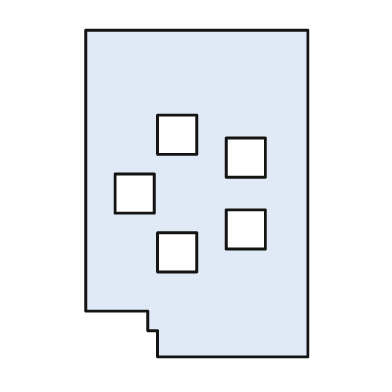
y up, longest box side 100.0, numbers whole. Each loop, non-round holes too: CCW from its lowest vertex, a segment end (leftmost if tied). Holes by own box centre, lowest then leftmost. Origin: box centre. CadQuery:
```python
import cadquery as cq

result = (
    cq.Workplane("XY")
    .moveTo(-12.0, -50.0)
    .lineTo(34.0, -50.0)
    .lineTo(34.0, 50.0)
    .lineTo(-34.0, 50.0)
    .lineTo(-34.0, -36.0)
    .lineTo(-15.0, -36.0)
    .lineTo(-15.0, -42.0)
    .lineTo(-12.0, -42.0)
    .close()
    .moveTo(-12.0, -24.0)
    .lineTo(0.0, -24.0)
    .lineTo(0.0, -12.0)
    .lineTo(-12.0, -12.0)
    .close()
    .moveTo(9.0, -17.0)
    .lineTo(21.0, -17.0)
    .lineTo(21.0, -5.0)
    .lineTo(9.0, -5.0)
    .close()
    .moveTo(-25.0, -6.0)
    .lineTo(-13.0, -6.0)
    .lineTo(-13.0, 6.0)
    .lineTo(-25.0, 6.0)
    .close()
    .moveTo(9.0, 5.0)
    .lineTo(21.0, 5.0)
    .lineTo(21.0, 17.0)
    .lineTo(9.0, 17.0)
    .close()
    .moveTo(-12.0, 12.0)
    .lineTo(0.0, 12.0)
    .lineTo(0.0, 24.0)
    .lineTo(-12.0, 24.0)
    .close()
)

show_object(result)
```